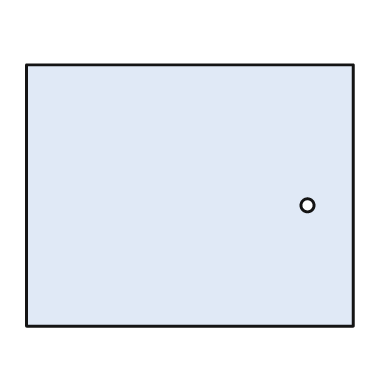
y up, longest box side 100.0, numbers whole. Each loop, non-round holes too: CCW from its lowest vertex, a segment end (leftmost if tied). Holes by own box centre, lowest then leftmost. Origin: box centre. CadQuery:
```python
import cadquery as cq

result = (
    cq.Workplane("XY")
    .moveTo(-50.0, -40.0)
    .lineTo(50.0, -40.0)
    .lineTo(50.0, 40.0)
    .lineTo(-50.0, 40.0)
    .close()
    .moveTo(36.0, -3.0)
    .circle(2.0)
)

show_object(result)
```